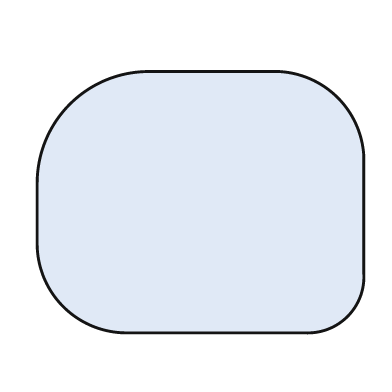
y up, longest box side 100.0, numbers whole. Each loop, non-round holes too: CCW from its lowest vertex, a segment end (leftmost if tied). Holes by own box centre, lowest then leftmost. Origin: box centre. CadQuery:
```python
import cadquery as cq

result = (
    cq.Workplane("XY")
    .moveTo(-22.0, -40.0)
    .lineTo(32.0, -40.0)
    .threePointArc((45.0, -35.0), (50.0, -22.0))
    .lineTo(50.0, 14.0)
    .threePointArc((42.0, 32.0), (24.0, 40.0))
    .lineTo(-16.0, 40.0)
    .threePointArc((-40.0, 30.0), (-50.0, 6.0))
    .lineTo(-50.0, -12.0)
    .threePointArc((-42.0, -32.0), (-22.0, -40.0))
    .close()
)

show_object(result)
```